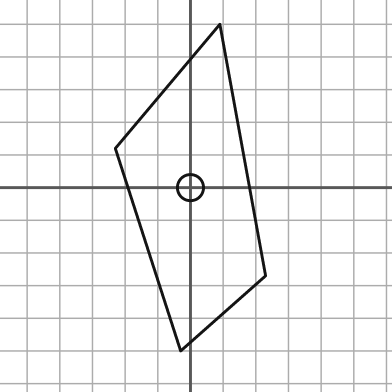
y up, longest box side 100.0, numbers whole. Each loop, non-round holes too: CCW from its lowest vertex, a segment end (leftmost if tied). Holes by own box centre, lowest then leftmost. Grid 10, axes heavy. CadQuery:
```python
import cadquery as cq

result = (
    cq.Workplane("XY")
    .moveTo(-3.0, -50.0)
    .lineTo(23.0, -27.0)
    .lineTo(9.0, 50.0)
    .lineTo(-23.0, 12.0)
    .close()
    .moveTo(0.0, 0.0)
    .circle(4.0)
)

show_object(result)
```